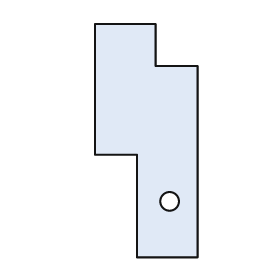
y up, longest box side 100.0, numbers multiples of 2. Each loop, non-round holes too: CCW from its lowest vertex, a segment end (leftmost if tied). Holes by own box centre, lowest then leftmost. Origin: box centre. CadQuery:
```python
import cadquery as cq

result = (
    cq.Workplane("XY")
    .moveTo(-4.0, -50.0)
    .lineTo(22.0, -50.0)
    .lineTo(22.0, 32.0)
    .lineTo(4.0, 32.0)
    .lineTo(4.0, 50.0)
    .lineTo(-22.0, 50.0)
    .lineTo(-22.0, -6.0)
    .lineTo(-4.0, -6.0)
    .close()
    .moveTo(10.0, -26.0)
    .circle(4.0)
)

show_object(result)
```